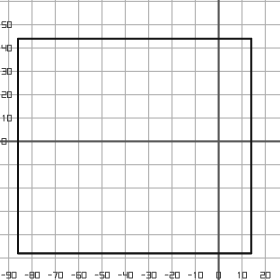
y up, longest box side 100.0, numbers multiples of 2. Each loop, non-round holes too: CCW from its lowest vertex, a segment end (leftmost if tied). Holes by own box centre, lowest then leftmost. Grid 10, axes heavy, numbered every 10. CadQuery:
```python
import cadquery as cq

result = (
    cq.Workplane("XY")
    .moveTo(-86.0, -48.0)
    .lineTo(14.0, -48.0)
    .lineTo(14.0, 44.0)
    .lineTo(-86.0, 44.0)
    .close()
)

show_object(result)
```